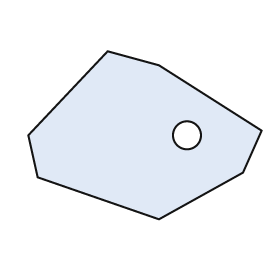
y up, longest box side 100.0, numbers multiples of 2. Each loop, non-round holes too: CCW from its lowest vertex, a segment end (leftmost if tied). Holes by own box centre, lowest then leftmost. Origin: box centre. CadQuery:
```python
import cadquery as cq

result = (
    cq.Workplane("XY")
    .moveTo(6.0, -36.0)
    .lineTo(42.0, -16.0)
    .lineTo(50.0, 2.0)
    .lineTo(6.0, 30.0)
    .lineTo(-16.0, 36.0)
    .lineTo(-50.0, 0.0)
    .lineTo(-46.0, -18.0)
    .close()
    .moveTo(18.0, 0.0)
    .circle(6.0)
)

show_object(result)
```